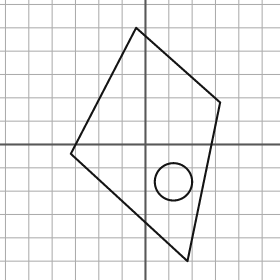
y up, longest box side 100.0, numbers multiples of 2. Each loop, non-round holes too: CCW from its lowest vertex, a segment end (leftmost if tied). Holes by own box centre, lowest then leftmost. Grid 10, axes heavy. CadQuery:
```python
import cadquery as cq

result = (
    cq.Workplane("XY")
    .moveTo(18.0, -50.0)
    .lineTo(32.0, 18.0)
    .lineTo(-4.0, 50.0)
    .lineTo(-32.0, -4.0)
    .close()
    .moveTo(12.0, -16.0)
    .circle(8.0)
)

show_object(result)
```